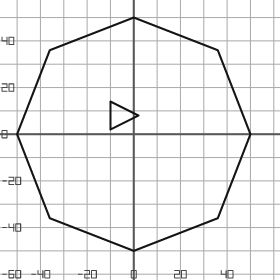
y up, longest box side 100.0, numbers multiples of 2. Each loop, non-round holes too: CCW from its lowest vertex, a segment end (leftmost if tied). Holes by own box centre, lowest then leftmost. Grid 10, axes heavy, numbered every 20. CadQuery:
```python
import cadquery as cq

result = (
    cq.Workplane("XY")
    .moveTo(0.0, -50.0)
    .lineTo(36.0, -36.0)
    .lineTo(50.0, 0.0)
    .lineTo(36.0, 36.0)
    .lineTo(0.0, 50.0)
    .lineTo(-36.0, 36.0)
    .lineTo(-50.0, 0.0)
    .lineTo(-36.0, -36.0)
    .close()
    .moveTo(-10.0, 2.0)
    .lineTo(2.0, 8.0)
    .lineTo(-10.0, 14.0)
    .close()
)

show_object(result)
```